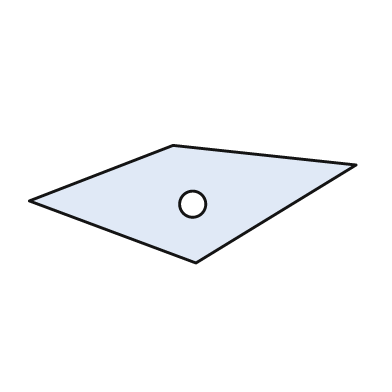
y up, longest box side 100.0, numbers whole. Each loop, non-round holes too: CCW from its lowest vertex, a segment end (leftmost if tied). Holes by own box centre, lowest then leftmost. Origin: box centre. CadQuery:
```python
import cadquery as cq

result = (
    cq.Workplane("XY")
    .moveTo(1.0, -18.0)
    .lineTo(50.0, 12.0)
    .lineTo(-6.0, 18.0)
    .lineTo(-50.0, 1.0)
    .close()
    .moveTo(0.0, 0.0)
    .circle(4.0)
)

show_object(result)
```